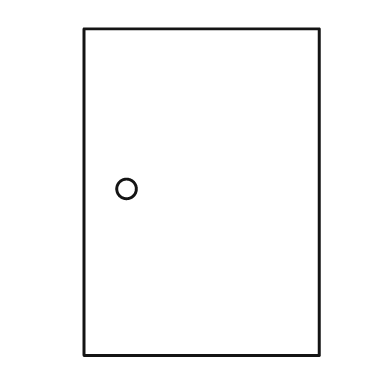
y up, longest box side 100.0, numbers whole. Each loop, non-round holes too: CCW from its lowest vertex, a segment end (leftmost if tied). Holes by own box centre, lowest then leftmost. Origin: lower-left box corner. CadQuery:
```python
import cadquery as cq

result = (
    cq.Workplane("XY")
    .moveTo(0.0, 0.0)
    .lineTo(72.0, 0.0)
    .lineTo(72.0, 100.0)
    .lineTo(0.0, 100.0)
    .close()
    .moveTo(13.0, 51.0)
    .circle(3.0)
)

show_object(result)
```